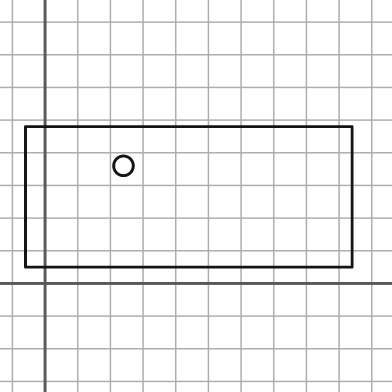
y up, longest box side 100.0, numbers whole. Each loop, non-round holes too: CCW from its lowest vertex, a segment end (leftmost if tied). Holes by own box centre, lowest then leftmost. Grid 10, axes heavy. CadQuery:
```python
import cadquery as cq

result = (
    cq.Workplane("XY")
    .moveTo(-6.0, 5.0)
    .lineTo(94.0, 5.0)
    .lineTo(94.0, 48.0)
    .lineTo(-6.0, 48.0)
    .close()
    .moveTo(24.0, 36.0)
    .circle(3.0)
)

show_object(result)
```